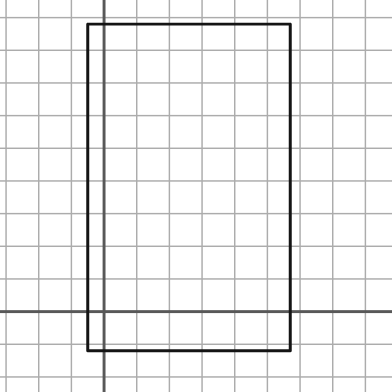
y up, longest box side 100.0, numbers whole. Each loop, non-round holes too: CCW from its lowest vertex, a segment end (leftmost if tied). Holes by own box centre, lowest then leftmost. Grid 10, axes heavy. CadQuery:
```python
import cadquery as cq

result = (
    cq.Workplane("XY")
    .moveTo(-5.0, -12.0)
    .lineTo(57.0, -12.0)
    .lineTo(57.0, 88.0)
    .lineTo(-5.0, 88.0)
    .close()
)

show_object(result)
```